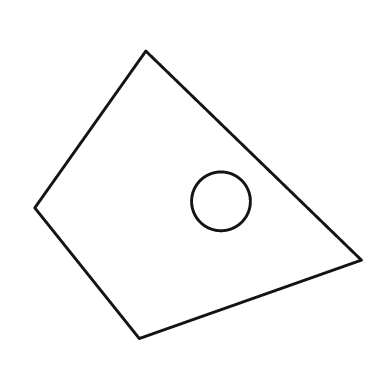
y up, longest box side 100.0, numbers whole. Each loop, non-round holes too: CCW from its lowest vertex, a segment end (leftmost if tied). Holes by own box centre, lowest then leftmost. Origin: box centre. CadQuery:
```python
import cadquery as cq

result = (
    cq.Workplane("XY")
    .moveTo(-18.0, -44.0)
    .lineTo(50.0, -20.0)
    .lineTo(-16.0, 44.0)
    .lineTo(-50.0, -4.0)
    .close()
    .moveTo(7.0, -2.0)
    .circle(9.0)
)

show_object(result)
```